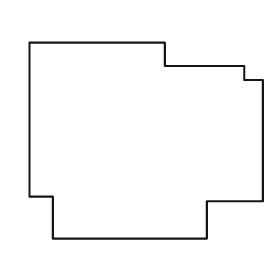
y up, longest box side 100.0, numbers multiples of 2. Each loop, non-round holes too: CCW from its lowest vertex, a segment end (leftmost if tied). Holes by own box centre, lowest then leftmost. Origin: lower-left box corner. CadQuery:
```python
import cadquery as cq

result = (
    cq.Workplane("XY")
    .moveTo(10.0, 0.0)
    .lineTo(76.0, 0.0)
    .lineTo(76.0, 16.0)
    .lineTo(100.0, 16.0)
    .lineTo(100.0, 68.0)
    .lineTo(92.0, 68.0)
    .lineTo(92.0, 74.0)
    .lineTo(58.0, 74.0)
    .lineTo(58.0, 84.0)
    .lineTo(0.0, 84.0)
    .lineTo(0.0, 18.0)
    .lineTo(10.0, 18.0)
    .close()
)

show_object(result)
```